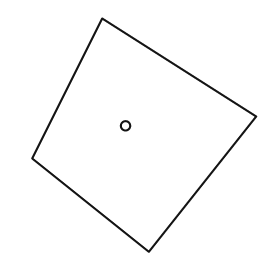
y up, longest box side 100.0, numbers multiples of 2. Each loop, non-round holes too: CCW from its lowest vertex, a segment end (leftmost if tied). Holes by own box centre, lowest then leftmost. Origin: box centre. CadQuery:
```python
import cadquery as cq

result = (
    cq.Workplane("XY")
    .moveTo(2.0, -50.0)
    .lineTo(48.0, 8.0)
    .lineTo(-18.0, 50.0)
    .lineTo(-48.0, -10.0)
    .close()
    .moveTo(-8.0, 4.0)
    .circle(2.0)
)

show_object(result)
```